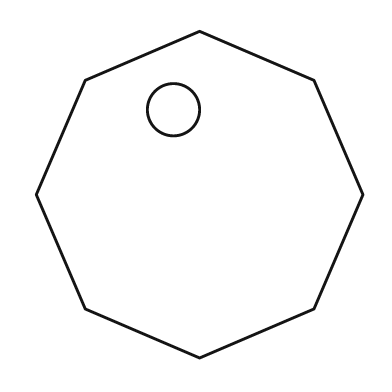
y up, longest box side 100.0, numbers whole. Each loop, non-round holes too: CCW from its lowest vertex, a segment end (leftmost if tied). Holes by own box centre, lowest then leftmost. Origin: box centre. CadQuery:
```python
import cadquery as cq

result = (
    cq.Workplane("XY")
    .moveTo(0.0, -50.0)
    .lineTo(35.0, -35.0)
    .lineTo(50.0, 0.0)
    .lineTo(35.0, 35.0)
    .lineTo(0.0, 50.0)
    .lineTo(-35.0, 35.0)
    .lineTo(-50.0, 0.0)
    .lineTo(-35.0, -35.0)
    .close()
    .moveTo(-8.0, 26.0)
    .circle(8.0)
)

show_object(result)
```